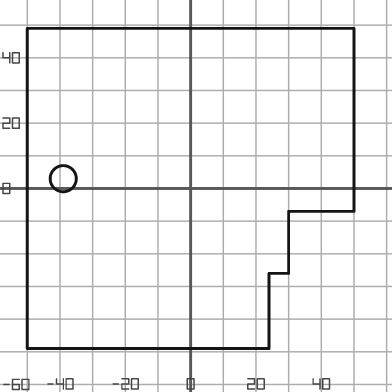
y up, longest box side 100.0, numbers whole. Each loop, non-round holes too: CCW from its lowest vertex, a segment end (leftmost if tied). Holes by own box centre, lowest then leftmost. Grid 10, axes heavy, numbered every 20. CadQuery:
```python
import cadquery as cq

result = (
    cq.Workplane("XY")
    .moveTo(-50.0, -49.0)
    .lineTo(24.0, -49.0)
    .lineTo(24.0, -26.0)
    .lineTo(30.0, -26.0)
    .lineTo(30.0, -7.0)
    .lineTo(50.0, -7.0)
    .lineTo(50.0, 49.0)
    .lineTo(-50.0, 49.0)
    .close()
    .moveTo(-39.0, 3.0)
    .circle(4.0)
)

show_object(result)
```